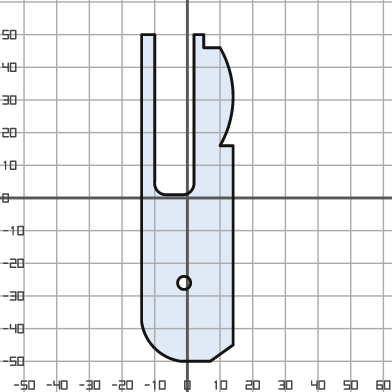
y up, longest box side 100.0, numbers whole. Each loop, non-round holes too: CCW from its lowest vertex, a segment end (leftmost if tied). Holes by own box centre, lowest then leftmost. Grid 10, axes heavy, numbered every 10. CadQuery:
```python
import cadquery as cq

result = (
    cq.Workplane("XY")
    .moveTo(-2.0, -50.0)
    .lineTo(7.0, -50.0)
    .lineTo(14.0, -45.0)
    .lineTo(14.0, 16.0)
    .lineTo(10.0, 16.0)
    .threePointArc((14.0, 31.0), (10.0, 46.0))
    .lineTo(5.0, 46.0)
    .lineTo(5.0, 50.0)
    .lineTo(2.0, 50.0)
    .lineTo(2.0, 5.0)
    .threePointArc((1.0, 2.0), (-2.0, 1.0))
    .lineTo(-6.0, 1.0)
    .threePointArc((-9.0, 2.0), (-10.0, 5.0))
    .lineTo(-10.0, 50.0)
    .lineTo(-14.0, 50.0)
    .lineTo(-14.0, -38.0)
    .threePointArc((-10.0, -46.0), (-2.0, -50.0))
    .close()
    .moveTo(-1.0, -26.0)
    .circle(2.0)
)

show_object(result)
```